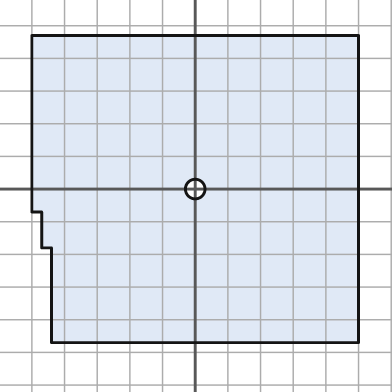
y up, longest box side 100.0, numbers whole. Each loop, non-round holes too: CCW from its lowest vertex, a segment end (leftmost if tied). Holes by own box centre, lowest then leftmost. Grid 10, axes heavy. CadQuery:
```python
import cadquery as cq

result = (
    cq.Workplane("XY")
    .moveTo(-44.0, -47.0)
    .lineTo(50.0, -47.0)
    .lineTo(50.0, 47.0)
    .lineTo(-50.0, 47.0)
    .lineTo(-50.0, -7.0)
    .lineTo(-47.0, -7.0)
    .lineTo(-47.0, -18.0)
    .lineTo(-44.0, -18.0)
    .close()
    .moveTo(0.0, 0.0)
    .circle(3.0)
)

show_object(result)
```